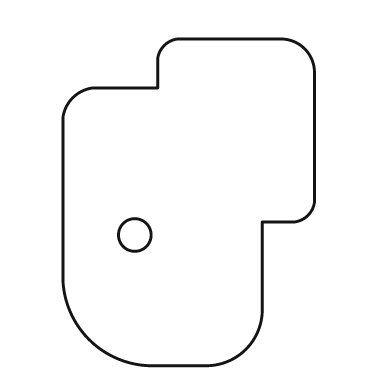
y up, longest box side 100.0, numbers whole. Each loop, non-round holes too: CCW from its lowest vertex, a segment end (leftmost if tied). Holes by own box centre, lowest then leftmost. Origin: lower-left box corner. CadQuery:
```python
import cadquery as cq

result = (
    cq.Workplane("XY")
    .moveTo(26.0, 0.0)
    .lineTo(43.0, 0.0)
    .threePointArc((56.0, 5.0), (61.0, 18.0))
    .lineTo(61.0, 44.0)
    .lineTo(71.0, 44.0)
    .threePointArc((75.0, 46.0), (77.0, 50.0))
    .lineTo(77.0, 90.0)
    .threePointArc((74.0, 97.0), (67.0, 100.0))
    .lineTo(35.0, 100.0)
    .threePointArc((31.0, 98.0), (29.0, 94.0))
    .lineTo(29.0, 85.0)
    .lineTo(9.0, 85.0)
    .threePointArc((3.0, 82.0), (0.0, 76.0))
    .lineTo(0.0, 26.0)
    .threePointArc((8.0, 8.0), (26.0, 0.0))
    .close()
    .moveTo(22.0, 40.0)
    .circle(5.0)
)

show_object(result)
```